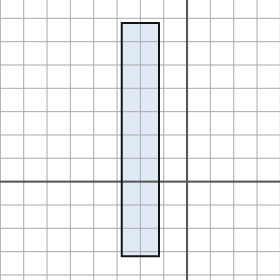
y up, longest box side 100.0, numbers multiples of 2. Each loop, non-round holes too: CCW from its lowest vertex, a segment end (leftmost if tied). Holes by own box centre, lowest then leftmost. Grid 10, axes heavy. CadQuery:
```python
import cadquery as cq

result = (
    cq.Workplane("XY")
    .moveTo(-28.0, -32.0)
    .lineTo(-12.0, -32.0)
    .lineTo(-12.0, 68.0)
    .lineTo(-28.0, 68.0)
    .close()
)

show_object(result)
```